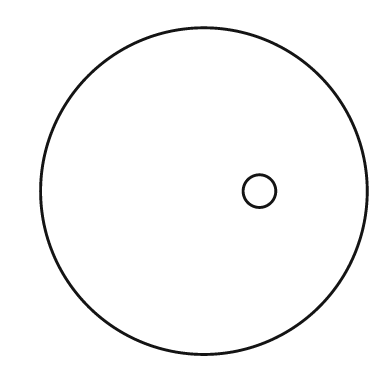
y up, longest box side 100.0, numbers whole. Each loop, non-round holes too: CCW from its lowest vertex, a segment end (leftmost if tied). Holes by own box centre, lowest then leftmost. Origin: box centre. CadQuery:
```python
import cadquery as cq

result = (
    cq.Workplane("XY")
    .moveTo(0.0, 0.0)
    .circle(50.0)
    .moveTo(17.0, 0.0)
    .circle(5.0)
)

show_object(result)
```